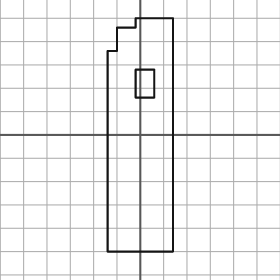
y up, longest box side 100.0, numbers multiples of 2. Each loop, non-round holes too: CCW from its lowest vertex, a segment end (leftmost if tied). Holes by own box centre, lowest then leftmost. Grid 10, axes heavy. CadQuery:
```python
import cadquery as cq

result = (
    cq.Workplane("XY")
    .moveTo(-14.0, -50.0)
    .lineTo(14.0, -50.0)
    .lineTo(14.0, 50.0)
    .lineTo(-2.0, 50.0)
    .lineTo(-2.0, 46.0)
    .lineTo(-10.0, 46.0)
    .lineTo(-10.0, 36.0)
    .lineTo(-14.0, 36.0)
    .close()
    .moveTo(-2.0, 16.0)
    .lineTo(6.0, 16.0)
    .lineTo(6.0, 28.0)
    .lineTo(-2.0, 28.0)
    .close()
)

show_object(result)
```